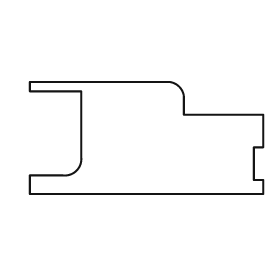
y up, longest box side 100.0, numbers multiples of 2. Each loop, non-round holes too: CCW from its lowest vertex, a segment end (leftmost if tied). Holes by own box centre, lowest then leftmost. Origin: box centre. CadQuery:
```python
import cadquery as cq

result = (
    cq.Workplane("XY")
    .moveTo(-50.0, -24.0)
    .lineTo(50.0, -24.0)
    .lineTo(50.0, -18.0)
    .lineTo(46.0, -18.0)
    .lineTo(46.0, -4.0)
    .lineTo(50.0, -4.0)
    .lineTo(50.0, 10.0)
    .lineTo(16.0, 10.0)
    .lineTo(16.0, 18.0)
    .threePointArc((14.0, 22.0), (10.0, 24.0))
    .lineTo(-50.0, 24.0)
    .lineTo(-50.0, 20.0)
    .lineTo(-28.0, 20.0)
    .lineTo(-28.0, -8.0)
    .threePointArc((-30.0, -14.0), (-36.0, -16.0))
    .lineTo(-50.0, -16.0)
    .close()
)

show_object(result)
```